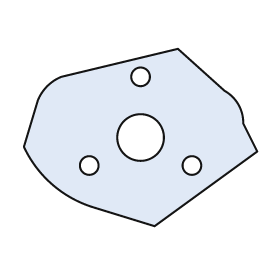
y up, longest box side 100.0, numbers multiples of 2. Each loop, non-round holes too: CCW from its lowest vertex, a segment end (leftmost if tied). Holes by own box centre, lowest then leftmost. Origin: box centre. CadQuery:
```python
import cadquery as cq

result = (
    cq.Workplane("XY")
    .moveTo(6.0, -38.0)
    .lineTo(50.0, -6.0)
    .lineTo(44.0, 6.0)
    .threePointArc((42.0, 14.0), (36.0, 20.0))
    .lineTo(16.0, 38.0)
    .lineTo(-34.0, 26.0)
    .threePointArc((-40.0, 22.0), (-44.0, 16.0))
    .lineTo(-50.0, -4.0)
    .threePointArc((-38.0, -20.0), (-20.0, -30.0))
    .close()
    .moveTo(-22.0, -12.0)
    .circle(4.0)
    .moveTo(22.0, -12.0)
    .circle(4.0)
    .moveTo(0.0, 0.0)
    .circle(10.0)
    .moveTo(0.0, 26.0)
    .circle(4.0)
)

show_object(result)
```